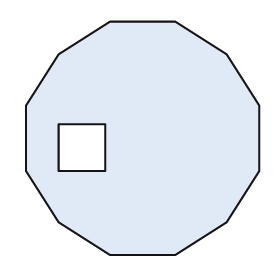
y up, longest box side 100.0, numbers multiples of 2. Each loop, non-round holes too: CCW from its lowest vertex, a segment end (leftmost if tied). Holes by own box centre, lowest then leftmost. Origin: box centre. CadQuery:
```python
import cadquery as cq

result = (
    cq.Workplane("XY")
    .moveTo(-14.0, -50.0)
    .lineTo(14.0, -50.0)
    .lineTo(36.0, -36.0)
    .lineTo(50.0, -14.0)
    .lineTo(50.0, 14.0)
    .lineTo(36.0, 36.0)
    .lineTo(14.0, 50.0)
    .lineTo(-14.0, 50.0)
    .lineTo(-36.0, 36.0)
    .lineTo(-50.0, 14.0)
    .lineTo(-50.0, -14.0)
    .lineTo(-36.0, -36.0)
    .close()
    .moveTo(-36.0, -14.0)
    .lineTo(-16.0, -14.0)
    .lineTo(-16.0, 6.0)
    .lineTo(-36.0, 6.0)
    .close()
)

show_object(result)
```